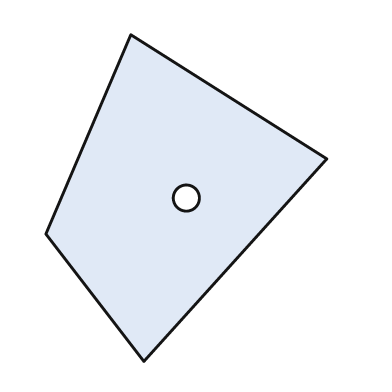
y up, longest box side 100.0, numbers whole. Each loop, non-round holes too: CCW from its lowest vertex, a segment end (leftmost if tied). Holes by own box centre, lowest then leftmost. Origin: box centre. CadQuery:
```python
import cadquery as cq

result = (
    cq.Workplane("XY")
    .moveTo(-13.0, -50.0)
    .lineTo(43.0, 12.0)
    .lineTo(-17.0, 50.0)
    .lineTo(-43.0, -11.0)
    .close()
    .moveTo(0.0, 0.0)
    .circle(4.0)
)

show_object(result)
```